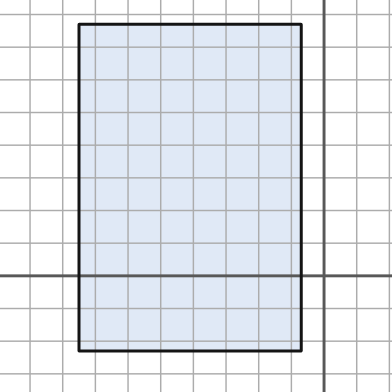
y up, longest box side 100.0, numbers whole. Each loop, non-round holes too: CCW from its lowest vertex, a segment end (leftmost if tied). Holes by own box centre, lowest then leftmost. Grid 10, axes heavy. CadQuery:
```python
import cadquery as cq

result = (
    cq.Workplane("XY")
    .moveTo(-75.0, -23.0)
    .lineTo(-7.0, -23.0)
    .lineTo(-7.0, 77.0)
    .lineTo(-75.0, 77.0)
    .close()
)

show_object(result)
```